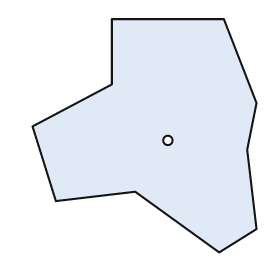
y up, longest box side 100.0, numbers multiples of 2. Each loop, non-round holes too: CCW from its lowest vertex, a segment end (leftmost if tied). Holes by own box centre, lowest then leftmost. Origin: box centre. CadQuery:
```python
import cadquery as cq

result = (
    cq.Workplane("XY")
    .moveTo(32.0, -50.0)
    .lineTo(48.0, -40.0)
    .lineTo(44.0, -6.0)
    .lineTo(48.0, 14.0)
    .lineTo(34.0, 50.0)
    .lineTo(-14.0, 50.0)
    .lineTo(-14.0, 22.0)
    .lineTo(-48.0, 4.0)
    .lineTo(-38.0, -28.0)
    .lineTo(-4.0, -24.0)
    .close()
    .moveTo(10.0, -2.0)
    .circle(2.0)
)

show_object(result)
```